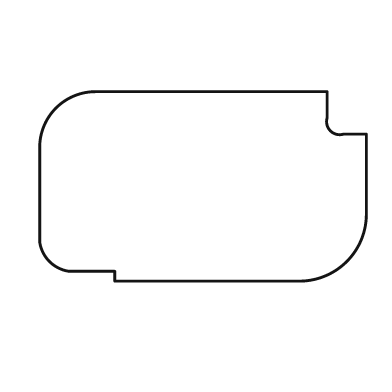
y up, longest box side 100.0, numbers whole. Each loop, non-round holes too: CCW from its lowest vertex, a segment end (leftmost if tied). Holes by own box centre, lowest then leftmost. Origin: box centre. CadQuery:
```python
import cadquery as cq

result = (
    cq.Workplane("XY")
    .moveTo(-27.0, -29.0)
    .lineTo(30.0, -29.0)
    .threePointArc((44.0, -23.0), (50.0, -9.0))
    .lineTo(50.0, 16.0)
    .lineTo(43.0, 16.0)
    .threePointArc((39.0, 17.0), (38.0, 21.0))
    .lineTo(38.0, 29.0)
    .lineTo(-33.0, 29.0)
    .threePointArc((-45.0, 24.0), (-50.0, 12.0))
    .lineTo(-50.0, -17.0)
    .threePointArc((-47.0, -23.0), (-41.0, -26.0))
    .lineTo(-27.0, -26.0)
    .close()
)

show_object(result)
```